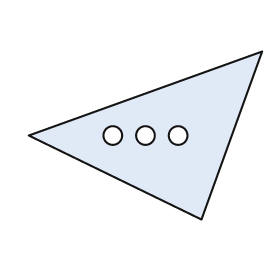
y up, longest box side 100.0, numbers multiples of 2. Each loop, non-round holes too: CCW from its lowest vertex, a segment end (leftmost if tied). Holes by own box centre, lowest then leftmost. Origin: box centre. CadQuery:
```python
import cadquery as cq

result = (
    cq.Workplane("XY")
    .moveTo(24.0, -36.0)
    .lineTo(50.0, 36.0)
    .lineTo(-50.0, 0.0)
    .close()
    .moveTo(-14.0, 0.0)
    .circle(4.0)
    .moveTo(0.0, 0.0)
    .circle(4.0)
    .moveTo(14.0, 0.0)
    .circle(4.0)
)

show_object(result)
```